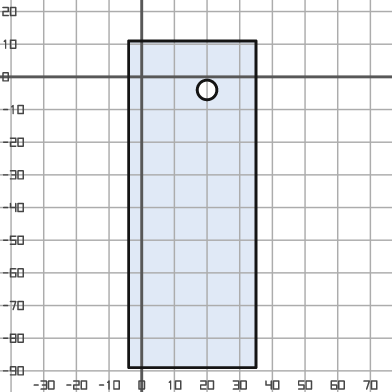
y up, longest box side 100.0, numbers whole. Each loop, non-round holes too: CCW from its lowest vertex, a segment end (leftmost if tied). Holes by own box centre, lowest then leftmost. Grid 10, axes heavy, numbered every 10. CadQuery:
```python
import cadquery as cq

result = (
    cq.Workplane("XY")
    .moveTo(-4.0, -89.0)
    .lineTo(35.0, -89.0)
    .lineTo(35.0, 11.0)
    .lineTo(-4.0, 11.0)
    .close()
    .moveTo(20.0, -4.0)
    .circle(3.0)
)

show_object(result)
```